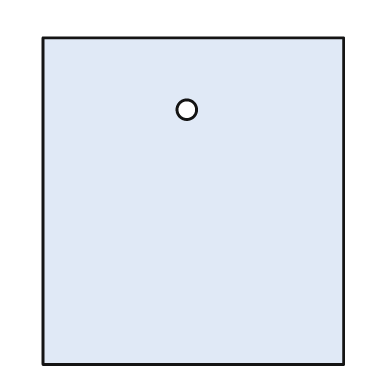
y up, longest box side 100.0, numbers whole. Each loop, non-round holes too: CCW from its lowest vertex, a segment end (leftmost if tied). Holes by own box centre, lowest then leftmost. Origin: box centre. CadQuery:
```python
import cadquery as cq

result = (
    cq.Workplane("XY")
    .moveTo(-46.0, -50.0)
    .lineTo(46.0, -50.0)
    .lineTo(46.0, 50.0)
    .lineTo(-46.0, 50.0)
    .close()
    .moveTo(-2.0, 28.0)
    .circle(3.0)
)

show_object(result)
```